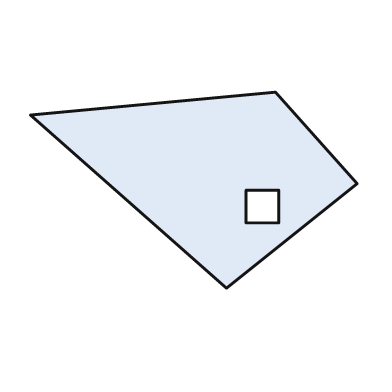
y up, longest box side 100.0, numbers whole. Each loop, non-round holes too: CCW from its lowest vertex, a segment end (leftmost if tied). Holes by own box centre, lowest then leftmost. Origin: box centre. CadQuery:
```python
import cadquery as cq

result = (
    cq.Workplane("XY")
    .moveTo(10.0, -30.0)
    .lineTo(50.0, 2.0)
    .lineTo(25.0, 30.0)
    .lineTo(-50.0, 23.0)
    .close()
    .moveTo(16.0, -10.0)
    .lineTo(26.0, -10.0)
    .lineTo(26.0, 0.0)
    .lineTo(16.0, 0.0)
    .close()
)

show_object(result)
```